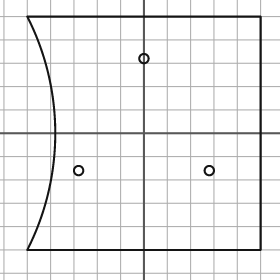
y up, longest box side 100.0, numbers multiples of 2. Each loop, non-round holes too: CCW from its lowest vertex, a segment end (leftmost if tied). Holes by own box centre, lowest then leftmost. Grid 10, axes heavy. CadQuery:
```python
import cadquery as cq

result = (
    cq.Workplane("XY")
    .moveTo(-50.0, -50.0)
    .lineTo(50.0, -50.0)
    .lineTo(50.0, 50.0)
    .lineTo(-50.0, 50.0)
    .threePointArc((-38.0, 0.0), (-50.0, -50.0))
    .close()
    .moveTo(-28.0, -16.0)
    .circle(2.0)
    .moveTo(28.0, -16.0)
    .circle(2.0)
    .moveTo(0.0, 32.0)
    .circle(2.0)
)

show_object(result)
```